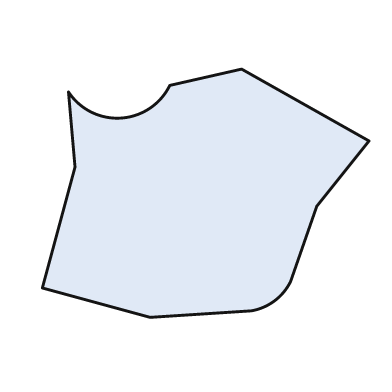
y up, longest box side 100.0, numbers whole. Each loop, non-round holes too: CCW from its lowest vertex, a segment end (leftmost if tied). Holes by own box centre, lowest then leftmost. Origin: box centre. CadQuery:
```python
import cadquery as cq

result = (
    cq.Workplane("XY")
    .moveTo(-17.0, -38.0)
    .lineTo(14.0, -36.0)
    .threePointArc((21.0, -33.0), (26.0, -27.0))
    .lineTo(34.0, -4.0)
    .lineTo(50.0, 16.0)
    .lineTo(11.0, 38.0)
    .lineTo(-11.0, 33.0)
    .threePointArc((-26.0, 23.0), (-42.0, 31.0))
    .lineTo(-40.0, 8.0)
    .lineTo(-50.0, -29.0)
    .close()
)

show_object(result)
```